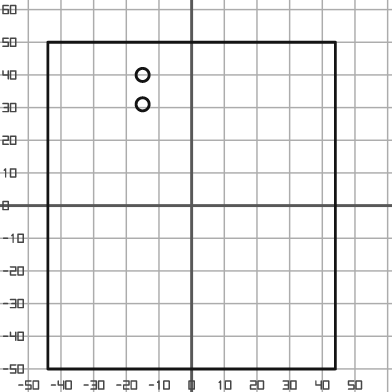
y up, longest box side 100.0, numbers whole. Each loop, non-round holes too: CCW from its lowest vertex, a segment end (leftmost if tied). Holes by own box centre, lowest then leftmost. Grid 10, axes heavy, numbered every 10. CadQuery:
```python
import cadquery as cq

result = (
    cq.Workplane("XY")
    .moveTo(-44.0, -50.0)
    .lineTo(44.0, -50.0)
    .lineTo(44.0, 50.0)
    .lineTo(-44.0, 50.0)
    .close()
    .moveTo(-15.0, 31.0)
    .circle(2.0)
    .moveTo(-15.0, 40.0)
    .circle(2.0)
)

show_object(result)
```